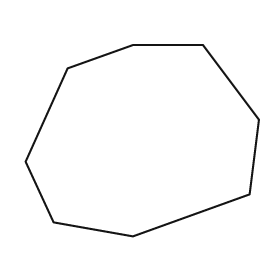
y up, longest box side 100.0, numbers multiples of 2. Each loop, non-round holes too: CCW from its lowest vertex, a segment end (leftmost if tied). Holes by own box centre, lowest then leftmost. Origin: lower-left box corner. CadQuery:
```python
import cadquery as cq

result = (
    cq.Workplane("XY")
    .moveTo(46.0, 0.0)
    .lineTo(96.0, 18.0)
    .lineTo(100.0, 50.0)
    .lineTo(76.0, 82.0)
    .lineTo(46.0, 82.0)
    .lineTo(18.0, 72.0)
    .lineTo(0.0, 32.0)
    .lineTo(12.0, 6.0)
    .close()
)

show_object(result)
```